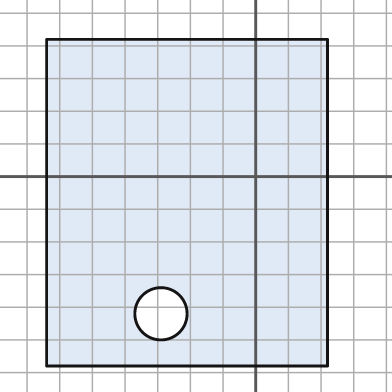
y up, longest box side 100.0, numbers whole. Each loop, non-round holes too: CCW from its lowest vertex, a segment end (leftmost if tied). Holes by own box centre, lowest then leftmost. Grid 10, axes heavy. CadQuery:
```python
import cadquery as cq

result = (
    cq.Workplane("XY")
    .moveTo(-64.0, -58.0)
    .lineTo(22.0, -58.0)
    .lineTo(22.0, 42.0)
    .lineTo(-64.0, 42.0)
    .close()
    .moveTo(-29.0, -42.0)
    .circle(8.0)
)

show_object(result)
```